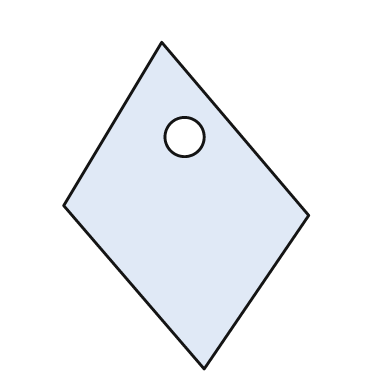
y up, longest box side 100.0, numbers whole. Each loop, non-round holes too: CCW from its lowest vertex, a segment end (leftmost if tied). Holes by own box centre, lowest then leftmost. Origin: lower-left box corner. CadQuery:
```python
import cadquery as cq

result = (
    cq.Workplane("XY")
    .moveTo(43.0, 0.0)
    .lineTo(75.0, 47.0)
    .lineTo(30.0, 100.0)
    .lineTo(0.0, 50.0)
    .close()
    .moveTo(37.0, 71.0)
    .circle(6.0)
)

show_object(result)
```